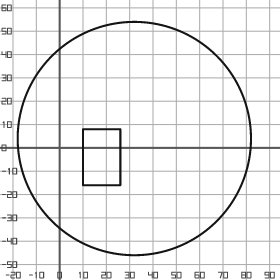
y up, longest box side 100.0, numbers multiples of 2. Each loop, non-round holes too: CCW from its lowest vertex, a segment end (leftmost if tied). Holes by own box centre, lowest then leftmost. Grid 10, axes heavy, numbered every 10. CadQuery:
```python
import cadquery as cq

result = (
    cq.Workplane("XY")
    .moveTo(32.0, 4.0)
    .circle(50.0)
    .moveTo(10.0, -16.0)
    .lineTo(26.0, -16.0)
    .lineTo(26.0, 8.0)
    .lineTo(10.0, 8.0)
    .close()
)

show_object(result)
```